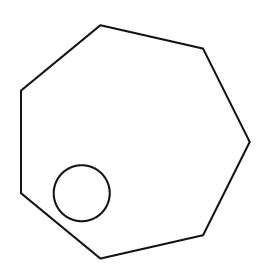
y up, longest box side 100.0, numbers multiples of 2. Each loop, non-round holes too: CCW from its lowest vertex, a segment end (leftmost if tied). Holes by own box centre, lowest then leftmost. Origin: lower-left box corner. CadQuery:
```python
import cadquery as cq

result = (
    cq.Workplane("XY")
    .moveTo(34.0, 0.0)
    .lineTo(78.0, 10.0)
    .lineTo(98.0, 50.0)
    .lineTo(78.0, 90.0)
    .lineTo(34.0, 100.0)
    .lineTo(0.0, 72.0)
    .lineTo(0.0, 28.0)
    .close()
    .moveTo(26.0, 28.0)
    .circle(12.0)
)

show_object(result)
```